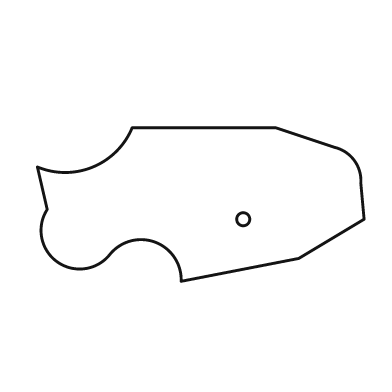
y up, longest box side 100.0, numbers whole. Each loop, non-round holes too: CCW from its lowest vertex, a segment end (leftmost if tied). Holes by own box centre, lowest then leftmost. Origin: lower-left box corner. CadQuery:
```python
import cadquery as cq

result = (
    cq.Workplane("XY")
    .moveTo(44.0, 0.0)
    .lineTo(80.0, 7.0)
    .lineTo(100.0, 19.0)
    .lineTo(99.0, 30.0)
    .threePointArc((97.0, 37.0), (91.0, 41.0))
    .lineTo(73.0, 47.0)
    .lineTo(29.0, 47.0)
    .threePointArc((17.0, 35.0), (0.0, 35.0))
    .lineTo(3.0, 22.0)
    .threePointArc((6.0, 6.0), (22.0, 8.0))
    .threePointArc((36.0, 12.0), (44.0, 0.0))
    .close()
    .moveTo(63.0, 19.0)
    .circle(2.0)
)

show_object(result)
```